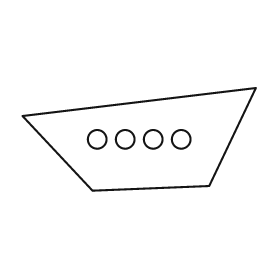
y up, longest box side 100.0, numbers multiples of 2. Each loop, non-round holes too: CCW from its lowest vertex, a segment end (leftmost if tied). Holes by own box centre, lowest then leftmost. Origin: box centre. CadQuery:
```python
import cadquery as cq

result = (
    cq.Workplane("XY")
    .moveTo(-20.0, -22.0)
    .lineTo(30.0, -20.0)
    .lineTo(50.0, 22.0)
    .lineTo(-50.0, 10.0)
    .close()
    .moveTo(-18.0, 0.0)
    .circle(4.0)
    .moveTo(-6.0, 0.0)
    .circle(4.0)
    .moveTo(6.0, 0.0)
    .circle(4.0)
    .moveTo(18.0, 0.0)
    .circle(4.0)
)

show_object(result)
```